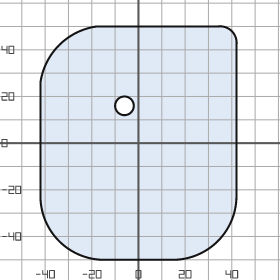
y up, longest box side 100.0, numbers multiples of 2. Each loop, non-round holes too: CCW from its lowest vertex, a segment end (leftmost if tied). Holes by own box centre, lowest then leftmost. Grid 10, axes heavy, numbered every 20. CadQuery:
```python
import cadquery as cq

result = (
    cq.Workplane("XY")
    .moveTo(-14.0, -50.0)
    .lineTo(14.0, -50.0)
    .threePointArc((34.0, -42.0), (42.0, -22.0))
    .lineTo(42.0, 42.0)
    .threePointArc((40.0, 48.0), (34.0, 50.0))
    .lineTo(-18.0, 50.0)
    .threePointArc((-34.0, 42.0), (-42.0, 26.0))
    .lineTo(-42.0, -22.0)
    .threePointArc((-34.0, -42.0), (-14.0, -50.0))
    .close()
    .moveTo(-6.0, 16.0)
    .circle(4.0)
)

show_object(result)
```